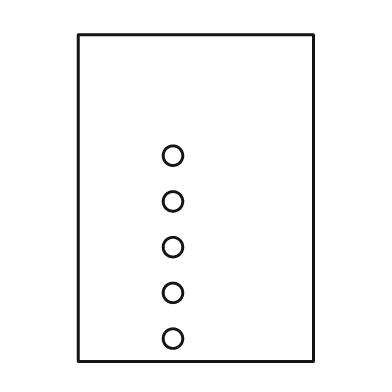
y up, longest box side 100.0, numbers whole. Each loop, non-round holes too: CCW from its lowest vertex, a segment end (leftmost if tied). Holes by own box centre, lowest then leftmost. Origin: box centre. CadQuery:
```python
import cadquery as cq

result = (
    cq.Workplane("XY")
    .moveTo(-36.0, -50.0)
    .lineTo(36.0, -50.0)
    .lineTo(36.0, 50.0)
    .lineTo(-36.0, 50.0)
    .close()
    .moveTo(-7.0, -43.0)
    .circle(3.0)
    .moveTo(-7.0, -29.0)
    .circle(3.0)
    .moveTo(-7.0, -15.0)
    .circle(3.0)
    .moveTo(-7.0, -1.0)
    .circle(3.0)
    .moveTo(-7.0, 13.0)
    .circle(3.0)
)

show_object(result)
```